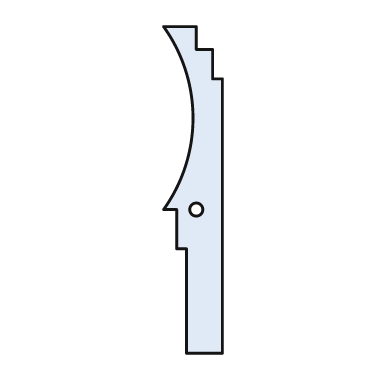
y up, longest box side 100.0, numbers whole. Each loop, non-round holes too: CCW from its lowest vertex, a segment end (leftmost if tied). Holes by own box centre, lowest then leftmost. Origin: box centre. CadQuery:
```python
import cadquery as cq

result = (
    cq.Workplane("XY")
    .moveTo(-2.0, -50.0)
    .lineTo(9.0, -50.0)
    .lineTo(9.0, 34.0)
    .lineTo(6.0, 34.0)
    .lineTo(6.0, 43.0)
    .lineTo(1.0, 43.0)
    .lineTo(1.0, 50.0)
    .lineTo(-9.0, 50.0)
    .threePointArc((0.0, 22.0), (-9.0, -6.0))
    .lineTo(-5.0, -6.0)
    .lineTo(-5.0, -18.0)
    .lineTo(-2.0, -18.0)
    .close()
    .moveTo(1.0, -6.0)
    .circle(2.0)
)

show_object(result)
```